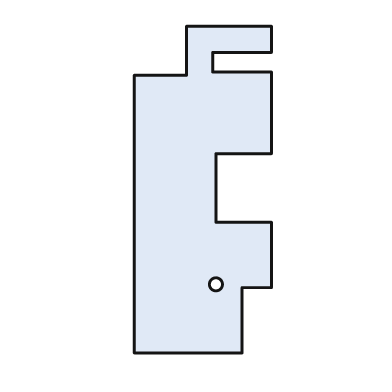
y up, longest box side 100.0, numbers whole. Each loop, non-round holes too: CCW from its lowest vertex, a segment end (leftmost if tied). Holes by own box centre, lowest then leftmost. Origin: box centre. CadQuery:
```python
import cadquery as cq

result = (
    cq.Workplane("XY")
    .moveTo(-21.0, -50.0)
    .lineTo(12.0, -50.0)
    .lineTo(12.0, -30.0)
    .lineTo(21.0, -30.0)
    .lineTo(21.0, -10.0)
    .lineTo(4.0, -10.0)
    .lineTo(4.0, 11.0)
    .lineTo(21.0, 11.0)
    .lineTo(21.0, 36.0)
    .lineTo(3.0, 36.0)
    .lineTo(3.0, 42.0)
    .lineTo(21.0, 42.0)
    .lineTo(21.0, 50.0)
    .lineTo(-5.0, 50.0)
    .lineTo(-5.0, 35.0)
    .lineTo(-21.0, 35.0)
    .close()
    .moveTo(4.0, -29.0)
    .circle(2.0)
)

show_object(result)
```